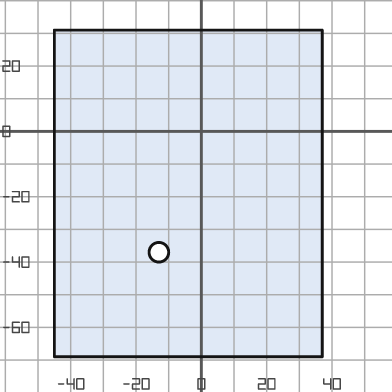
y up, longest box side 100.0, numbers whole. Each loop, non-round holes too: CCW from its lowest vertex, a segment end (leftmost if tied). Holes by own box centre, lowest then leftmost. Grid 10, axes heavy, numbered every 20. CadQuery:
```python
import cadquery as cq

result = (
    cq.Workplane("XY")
    .moveTo(-45.0, -69.0)
    .lineTo(37.0, -69.0)
    .lineTo(37.0, 31.0)
    .lineTo(-45.0, 31.0)
    .close()
    .moveTo(-13.0, -37.0)
    .circle(3.0)
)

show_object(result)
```